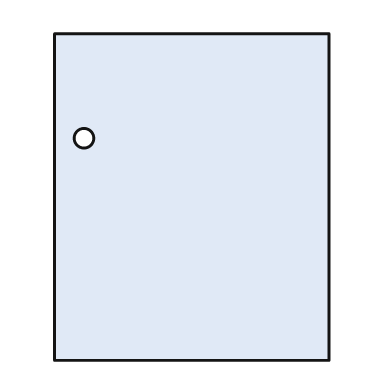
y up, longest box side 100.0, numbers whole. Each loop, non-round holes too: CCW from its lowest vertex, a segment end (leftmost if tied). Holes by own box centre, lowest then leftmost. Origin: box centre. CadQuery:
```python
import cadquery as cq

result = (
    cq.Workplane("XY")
    .moveTo(-42.0, -50.0)
    .lineTo(42.0, -50.0)
    .lineTo(42.0, 50.0)
    .lineTo(-42.0, 50.0)
    .close()
    .moveTo(-33.0, 18.0)
    .circle(3.0)
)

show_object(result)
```